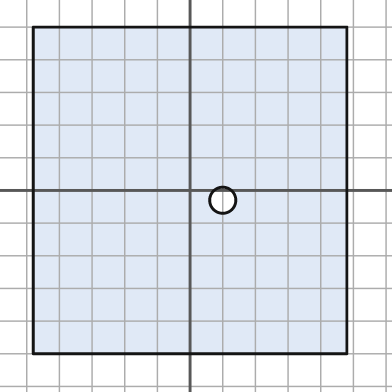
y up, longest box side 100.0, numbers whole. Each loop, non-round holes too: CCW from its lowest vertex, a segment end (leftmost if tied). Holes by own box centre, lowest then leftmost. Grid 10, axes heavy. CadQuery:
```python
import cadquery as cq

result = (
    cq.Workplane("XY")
    .moveTo(-48.0, -50.0)
    .lineTo(48.0, -50.0)
    .lineTo(48.0, 50.0)
    .lineTo(-48.0, 50.0)
    .close()
    .moveTo(10.0, -3.0)
    .circle(4.0)
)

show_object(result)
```